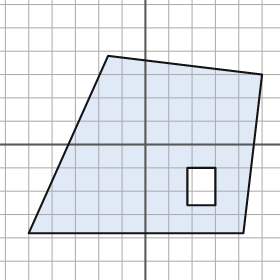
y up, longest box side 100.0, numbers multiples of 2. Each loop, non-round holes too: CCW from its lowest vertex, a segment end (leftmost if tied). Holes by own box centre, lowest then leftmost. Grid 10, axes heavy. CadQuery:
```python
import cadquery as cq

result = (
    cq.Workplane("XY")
    .moveTo(-50.0, -38.0)
    .lineTo(42.0, -38.0)
    .lineTo(50.0, 30.0)
    .lineTo(-16.0, 38.0)
    .close()
    .moveTo(18.0, -26.0)
    .lineTo(30.0, -26.0)
    .lineTo(30.0, -10.0)
    .lineTo(18.0, -10.0)
    .close()
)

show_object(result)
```